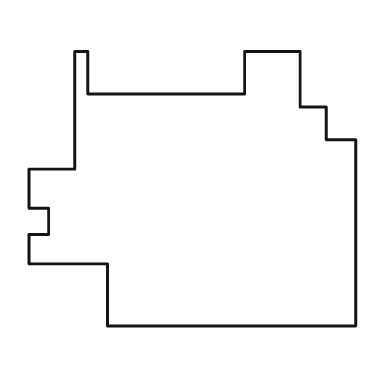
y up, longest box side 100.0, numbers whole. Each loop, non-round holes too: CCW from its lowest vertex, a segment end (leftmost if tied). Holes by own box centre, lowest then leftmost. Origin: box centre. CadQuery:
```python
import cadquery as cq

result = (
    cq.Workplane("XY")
    .moveTo(-26.0, -42.0)
    .lineTo(50.0, -42.0)
    .lineTo(50.0, 15.0)
    .lineTo(41.0, 15.0)
    .lineTo(41.0, 25.0)
    .lineTo(33.0, 25.0)
    .lineTo(33.0, 42.0)
    .lineTo(16.0, 42.0)
    .lineTo(16.0, 29.0)
    .lineTo(-32.0, 29.0)
    .lineTo(-32.0, 42.0)
    .lineTo(-36.0, 42.0)
    .lineTo(-36.0, 6.0)
    .lineTo(-50.0, 6.0)
    .lineTo(-50.0, -6.0)
    .lineTo(-44.0, -6.0)
    .lineTo(-44.0, -14.0)
    .lineTo(-50.0, -14.0)
    .lineTo(-50.0, -23.0)
    .lineTo(-26.0, -23.0)
    .close()
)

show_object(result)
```